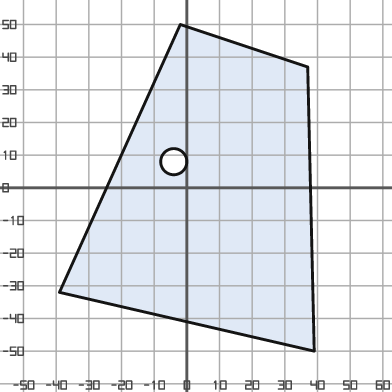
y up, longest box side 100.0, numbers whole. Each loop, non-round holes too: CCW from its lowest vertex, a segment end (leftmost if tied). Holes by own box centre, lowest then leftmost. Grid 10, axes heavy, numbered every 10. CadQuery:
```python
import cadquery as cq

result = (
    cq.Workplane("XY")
    .moveTo(39.0, -50.0)
    .lineTo(37.0, 37.0)
    .lineTo(-2.0, 50.0)
    .lineTo(-39.0, -32.0)
    .close()
    .moveTo(-4.0, 8.0)
    .circle(4.0)
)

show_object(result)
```